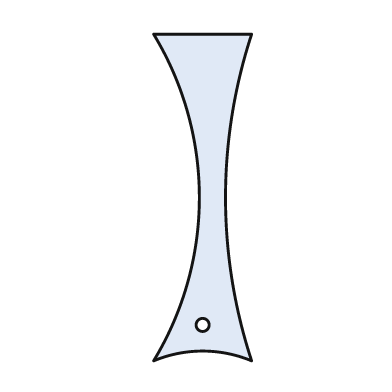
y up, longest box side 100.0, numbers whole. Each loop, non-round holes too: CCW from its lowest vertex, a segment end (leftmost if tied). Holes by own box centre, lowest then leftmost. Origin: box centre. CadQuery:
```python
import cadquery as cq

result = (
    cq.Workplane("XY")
    .moveTo(-15.0, -50.0)
    .threePointArc((0.0, -47.0), (15.0, -50.0))
    .threePointArc((7.0, 0.0), (15.0, 50.0))
    .lineTo(-15.0, 50.0)
    .threePointArc((-1.0, 0.0), (-15.0, -50.0))
    .close()
    .moveTo(0.0, -39.0)
    .circle(2.0)
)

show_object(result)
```